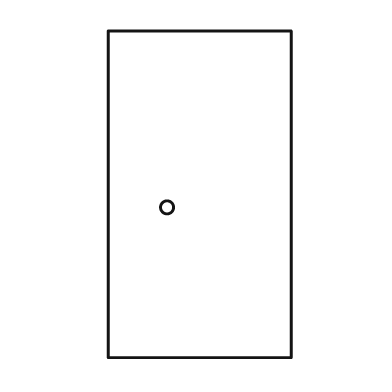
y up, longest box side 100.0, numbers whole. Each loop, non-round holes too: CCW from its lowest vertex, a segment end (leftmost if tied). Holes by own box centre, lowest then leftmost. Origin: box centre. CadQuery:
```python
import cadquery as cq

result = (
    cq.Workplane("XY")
    .moveTo(-28.0, -50.0)
    .lineTo(28.0, -50.0)
    .lineTo(28.0, 50.0)
    .lineTo(-28.0, 50.0)
    .close()
    .moveTo(-10.0, -4.0)
    .circle(2.0)
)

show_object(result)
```